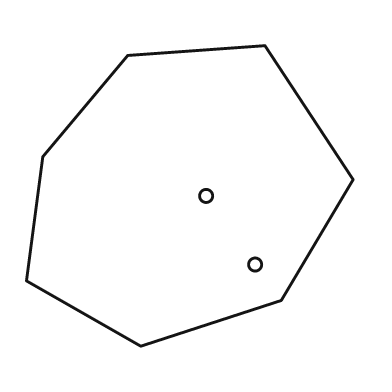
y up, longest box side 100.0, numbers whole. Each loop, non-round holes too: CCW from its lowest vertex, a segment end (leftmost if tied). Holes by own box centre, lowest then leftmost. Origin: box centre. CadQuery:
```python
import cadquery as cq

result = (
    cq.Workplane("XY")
    .moveTo(-15.0, -46.0)
    .lineTo(28.0, -32.0)
    .lineTo(50.0, 5.0)
    .lineTo(23.0, 46.0)
    .lineTo(-19.0, 43.0)
    .lineTo(-45.0, 12.0)
    .lineTo(-50.0, -26.0)
    .close()
    .moveTo(20.0, -21.0)
    .circle(2.0)
    .moveTo(5.0, 0.0)
    .circle(2.0)
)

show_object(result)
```